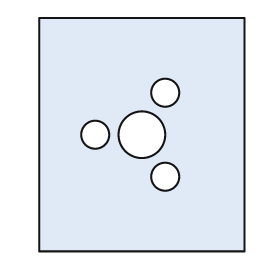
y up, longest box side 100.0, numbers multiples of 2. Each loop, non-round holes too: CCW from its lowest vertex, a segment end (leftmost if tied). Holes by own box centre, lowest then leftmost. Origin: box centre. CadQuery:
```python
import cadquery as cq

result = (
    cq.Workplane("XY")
    .moveTo(-44.0, -50.0)
    .lineTo(44.0, -50.0)
    .lineTo(44.0, 50.0)
    .lineTo(-44.0, 50.0)
    .close()
    .moveTo(10.0, -18.0)
    .circle(6.0)
    .moveTo(-20.0, 0.0)
    .circle(6.0)
    .moveTo(0.0, 0.0)
    .circle(10.0)
    .moveTo(10.0, 18.0)
    .circle(6.0)
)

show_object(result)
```